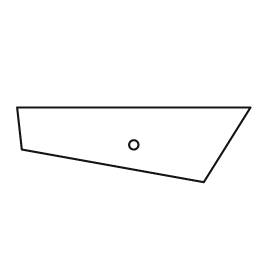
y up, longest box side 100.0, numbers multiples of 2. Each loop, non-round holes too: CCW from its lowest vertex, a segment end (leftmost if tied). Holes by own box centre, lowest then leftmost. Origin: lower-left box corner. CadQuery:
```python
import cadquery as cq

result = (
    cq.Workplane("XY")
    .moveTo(80.0, 0.0)
    .lineTo(100.0, 32.0)
    .lineTo(0.0, 32.0)
    .lineTo(2.0, 14.0)
    .close()
    .moveTo(50.0, 16.0)
    .circle(2.0)
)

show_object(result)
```